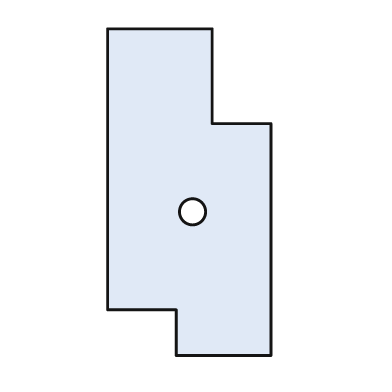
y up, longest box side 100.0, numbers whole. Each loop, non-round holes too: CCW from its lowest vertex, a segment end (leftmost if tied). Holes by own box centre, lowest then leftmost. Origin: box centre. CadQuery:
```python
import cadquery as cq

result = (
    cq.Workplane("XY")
    .moveTo(-4.0, -50.0)
    .lineTo(25.0, -50.0)
    .lineTo(25.0, 21.0)
    .lineTo(7.0, 21.0)
    .lineTo(7.0, 50.0)
    .lineTo(-25.0, 50.0)
    .lineTo(-25.0, -36.0)
    .lineTo(-4.0, -36.0)
    .close()
    .moveTo(1.0, -6.0)
    .circle(4.0)
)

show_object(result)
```